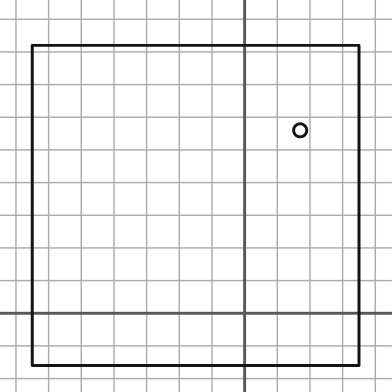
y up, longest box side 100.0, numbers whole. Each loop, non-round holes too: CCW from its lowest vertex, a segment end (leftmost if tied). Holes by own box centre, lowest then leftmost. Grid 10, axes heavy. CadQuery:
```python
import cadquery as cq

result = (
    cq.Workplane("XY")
    .moveTo(-65.0, -16.0)
    .lineTo(35.0, -16.0)
    .lineTo(35.0, 82.0)
    .lineTo(-65.0, 82.0)
    .close()
    .moveTo(17.0, 56.0)
    .circle(2.0)
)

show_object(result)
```